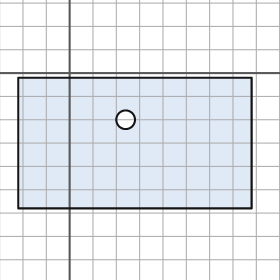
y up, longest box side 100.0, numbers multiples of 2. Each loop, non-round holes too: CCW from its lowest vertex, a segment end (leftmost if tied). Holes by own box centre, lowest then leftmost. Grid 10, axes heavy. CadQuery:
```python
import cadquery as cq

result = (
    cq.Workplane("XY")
    .moveTo(-22.0, -58.0)
    .lineTo(78.0, -58.0)
    .lineTo(78.0, -2.0)
    .lineTo(-22.0, -2.0)
    .close()
    .moveTo(24.0, -20.0)
    .circle(4.0)
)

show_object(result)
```